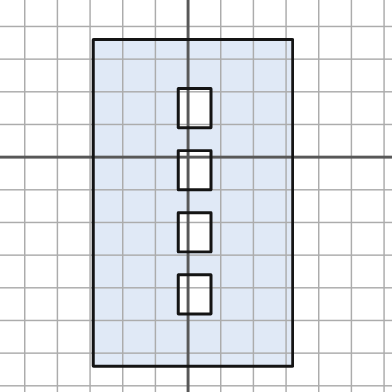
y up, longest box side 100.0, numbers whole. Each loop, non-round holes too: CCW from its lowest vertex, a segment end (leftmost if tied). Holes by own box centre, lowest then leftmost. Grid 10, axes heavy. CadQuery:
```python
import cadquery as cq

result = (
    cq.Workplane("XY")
    .moveTo(-29.0, -64.0)
    .lineTo(32.0, -64.0)
    .lineTo(32.0, 36.0)
    .lineTo(-29.0, 36.0)
    .close()
    .moveTo(-3.0, -48.0)
    .lineTo(7.0, -48.0)
    .lineTo(7.0, -36.0)
    .lineTo(-3.0, -36.0)
    .close()
    .moveTo(-3.0, -29.0)
    .lineTo(7.0, -29.0)
    .lineTo(7.0, -17.0)
    .lineTo(-3.0, -17.0)
    .close()
    .moveTo(-3.0, -10.0)
    .lineTo(7.0, -10.0)
    .lineTo(7.0, 2.0)
    .lineTo(-3.0, 2.0)
    .close()
    .moveTo(-3.0, 9.0)
    .lineTo(7.0, 9.0)
    .lineTo(7.0, 21.0)
    .lineTo(-3.0, 21.0)
    .close()
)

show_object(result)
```